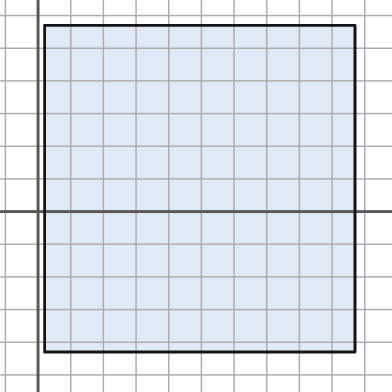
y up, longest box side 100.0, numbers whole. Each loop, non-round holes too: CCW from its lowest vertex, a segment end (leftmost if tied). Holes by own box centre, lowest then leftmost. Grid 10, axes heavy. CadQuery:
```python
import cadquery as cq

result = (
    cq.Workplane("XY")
    .moveTo(2.0, -43.0)
    .lineTo(97.0, -43.0)
    .lineTo(97.0, 57.0)
    .lineTo(2.0, 57.0)
    .close()
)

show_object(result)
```